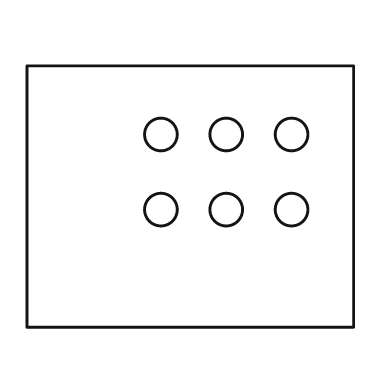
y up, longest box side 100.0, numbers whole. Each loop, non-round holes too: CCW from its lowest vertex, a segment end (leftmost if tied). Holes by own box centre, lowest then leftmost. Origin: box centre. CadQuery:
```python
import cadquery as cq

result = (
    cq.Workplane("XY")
    .moveTo(-50.0, -40.0)
    .lineTo(50.0, -40.0)
    .lineTo(50.0, 40.0)
    .lineTo(-50.0, 40.0)
    .close()
    .moveTo(-9.0, -4.0)
    .circle(5.0)
    .moveTo(11.0, -4.0)
    .circle(5.0)
    .moveTo(31.0, -4.0)
    .circle(5.0)
    .moveTo(-9.0, 19.0)
    .circle(5.0)
    .moveTo(11.0, 19.0)
    .circle(5.0)
    .moveTo(31.0, 19.0)
    .circle(5.0)
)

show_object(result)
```